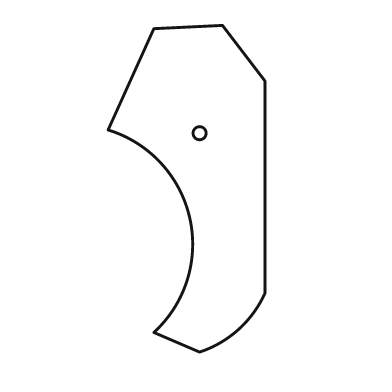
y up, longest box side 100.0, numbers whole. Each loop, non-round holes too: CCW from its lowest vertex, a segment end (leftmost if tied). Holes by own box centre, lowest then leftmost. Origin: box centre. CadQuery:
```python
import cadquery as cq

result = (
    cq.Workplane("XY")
    .moveTo(4.0, -50.0)
    .threePointArc((16.0, -43.0), (24.0, -32.0))
    .lineTo(24.0, 33.0)
    .lineTo(11.0, 50.0)
    .lineTo(-10.0, 49.0)
    .lineTo(-24.0, 18.0)
    .threePointArc((1.0, -9.0), (-10.0, -44.0))
    .close()
    .moveTo(4.0, 17.0)
    .circle(2.0)
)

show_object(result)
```